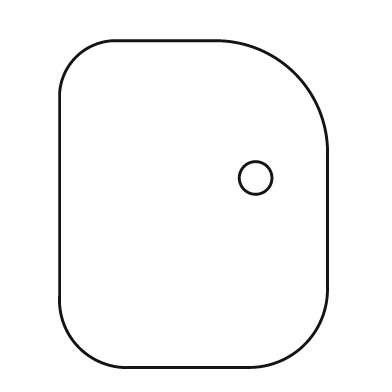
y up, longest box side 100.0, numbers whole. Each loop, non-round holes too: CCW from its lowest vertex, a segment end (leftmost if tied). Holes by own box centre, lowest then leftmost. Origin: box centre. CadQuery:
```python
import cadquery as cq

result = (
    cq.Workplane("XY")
    .moveTo(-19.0, -50.0)
    .lineTo(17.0, -50.0)
    .threePointArc((34.0, -43.0), (41.0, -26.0))
    .lineTo(41.0, 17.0)
    .threePointArc((31.0, 40.0), (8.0, 50.0))
    .lineTo(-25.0, 50.0)
    .threePointArc((-36.0, 45.0), (-41.0, 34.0))
    .lineTo(-41.0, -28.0)
    .threePointArc((-35.0, -44.0), (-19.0, -50.0))
    .close()
    .moveTo(19.0, 8.0)
    .circle(5.0)
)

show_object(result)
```